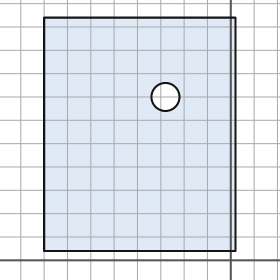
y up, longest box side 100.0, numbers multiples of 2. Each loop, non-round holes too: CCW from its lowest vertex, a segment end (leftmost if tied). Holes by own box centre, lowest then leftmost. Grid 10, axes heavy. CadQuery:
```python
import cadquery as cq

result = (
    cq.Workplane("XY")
    .moveTo(-80.0, 4.0)
    .lineTo(2.0, 4.0)
    .lineTo(2.0, 104.0)
    .lineTo(-80.0, 104.0)
    .close()
    .moveTo(-28.0, 70.0)
    .circle(6.0)
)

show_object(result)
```